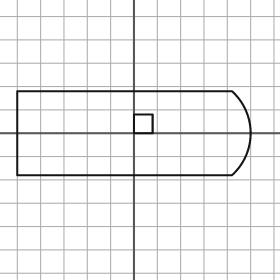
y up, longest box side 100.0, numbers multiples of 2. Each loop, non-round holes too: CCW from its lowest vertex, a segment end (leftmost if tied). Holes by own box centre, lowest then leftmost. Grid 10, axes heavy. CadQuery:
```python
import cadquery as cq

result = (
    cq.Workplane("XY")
    .moveTo(-50.0, -18.0)
    .lineTo(42.0, -18.0)
    .threePointArc((50.0, 0.0), (42.0, 18.0))
    .lineTo(-50.0, 18.0)
    .close()
    .moveTo(0.0, 0.0)
    .lineTo(8.0, 0.0)
    .lineTo(8.0, 8.0)
    .lineTo(0.0, 8.0)
    .close()
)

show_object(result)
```